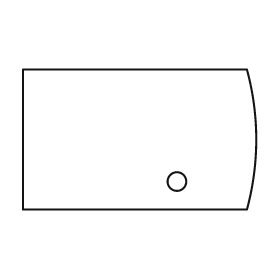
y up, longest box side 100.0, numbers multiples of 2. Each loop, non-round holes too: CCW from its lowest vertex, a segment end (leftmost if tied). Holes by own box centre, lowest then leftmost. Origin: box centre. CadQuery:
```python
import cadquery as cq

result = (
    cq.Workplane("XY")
    .moveTo(-50.0, -30.0)
    .lineTo(46.0, -30.0)
    .threePointArc((50.0, 0.0), (46.0, 30.0))
    .lineTo(-50.0, 30.0)
    .close()
    .moveTo(16.0, -18.0)
    .circle(4.0)
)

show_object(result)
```